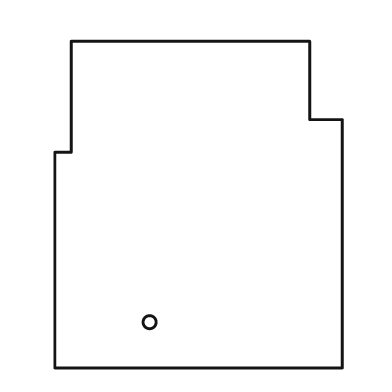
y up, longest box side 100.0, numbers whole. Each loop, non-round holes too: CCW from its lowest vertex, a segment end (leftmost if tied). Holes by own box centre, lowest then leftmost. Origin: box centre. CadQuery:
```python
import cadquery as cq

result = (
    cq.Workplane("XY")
    .moveTo(-44.0, -50.0)
    .lineTo(44.0, -50.0)
    .lineTo(44.0, 26.0)
    .lineTo(34.0, 26.0)
    .lineTo(34.0, 50.0)
    .lineTo(-39.0, 50.0)
    .lineTo(-39.0, 16.0)
    .lineTo(-44.0, 16.0)
    .close()
    .moveTo(-15.0, -36.0)
    .circle(2.0)
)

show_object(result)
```